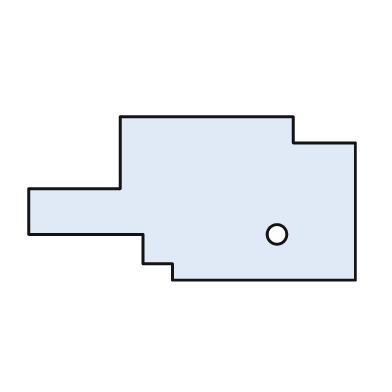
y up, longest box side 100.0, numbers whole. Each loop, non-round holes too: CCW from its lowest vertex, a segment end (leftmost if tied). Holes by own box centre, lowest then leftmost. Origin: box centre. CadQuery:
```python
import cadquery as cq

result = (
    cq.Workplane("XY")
    .moveTo(-6.0, -25.0)
    .lineTo(50.0, -25.0)
    .lineTo(50.0, 17.0)
    .lineTo(31.0, 17.0)
    .lineTo(31.0, 25.0)
    .lineTo(-22.0, 25.0)
    .lineTo(-22.0, 3.0)
    .lineTo(-50.0, 3.0)
    .lineTo(-50.0, -11.0)
    .lineTo(-15.0, -11.0)
    .lineTo(-15.0, -20.0)
    .lineTo(-6.0, -20.0)
    .close()
    .moveTo(26.0, -11.0)
    .circle(3.0)
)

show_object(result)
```